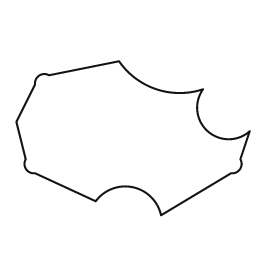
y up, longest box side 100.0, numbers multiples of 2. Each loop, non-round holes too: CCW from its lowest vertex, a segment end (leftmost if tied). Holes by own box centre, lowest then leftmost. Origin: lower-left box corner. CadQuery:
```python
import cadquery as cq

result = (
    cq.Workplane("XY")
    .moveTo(62.0, 0.0)
    .lineTo(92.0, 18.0)
    .threePointArc((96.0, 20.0), (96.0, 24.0))
    .lineTo(100.0, 36.0)
    .threePointArc((82.0, 36.0), (80.0, 54.0))
    .threePointArc((60.0, 54.0), (44.0, 66.0))
    .lineTo(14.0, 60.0)
    .threePointArc((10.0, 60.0), (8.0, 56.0))
    .lineTo(0.0, 40.0)
    .lineTo(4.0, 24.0)
    .threePointArc((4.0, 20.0), (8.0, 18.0))
    .lineTo(34.0, 6.0)
    .threePointArc((50.0, 12.0), (62.0, 0.0))
    .close()
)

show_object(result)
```